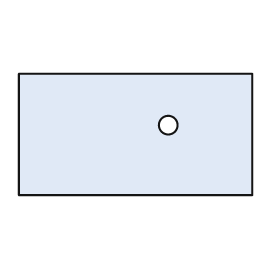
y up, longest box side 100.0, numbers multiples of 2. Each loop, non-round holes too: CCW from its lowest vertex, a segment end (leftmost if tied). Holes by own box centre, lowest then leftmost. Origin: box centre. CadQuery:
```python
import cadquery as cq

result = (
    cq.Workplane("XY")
    .moveTo(-50.0, -26.0)
    .lineTo(50.0, -26.0)
    .lineTo(50.0, 26.0)
    .lineTo(-50.0, 26.0)
    .close()
    .moveTo(14.0, 4.0)
    .circle(4.0)
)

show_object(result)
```